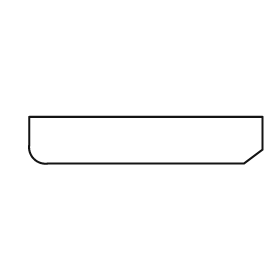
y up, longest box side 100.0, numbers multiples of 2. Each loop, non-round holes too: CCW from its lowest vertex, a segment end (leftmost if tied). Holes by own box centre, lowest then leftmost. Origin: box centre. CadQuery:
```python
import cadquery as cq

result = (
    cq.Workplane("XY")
    .moveTo(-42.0, -10.0)
    .lineTo(42.0, -10.0)
    .lineTo(50.0, -4.0)
    .lineTo(50.0, 10.0)
    .lineTo(-50.0, 10.0)
    .lineTo(-50.0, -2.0)
    .threePointArc((-48.0, -8.0), (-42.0, -10.0))
    .close()
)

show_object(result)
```